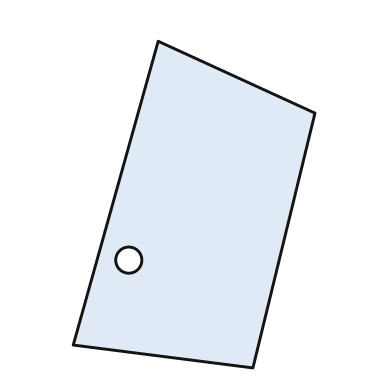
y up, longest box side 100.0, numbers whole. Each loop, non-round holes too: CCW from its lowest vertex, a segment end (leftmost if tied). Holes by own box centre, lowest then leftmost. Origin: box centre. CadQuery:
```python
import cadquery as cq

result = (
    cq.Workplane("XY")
    .moveTo(18.0, -50.0)
    .lineTo(37.0, 28.0)
    .lineTo(-11.0, 50.0)
    .lineTo(-37.0, -43.0)
    .close()
    .moveTo(-20.0, -17.0)
    .circle(4.0)
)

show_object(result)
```